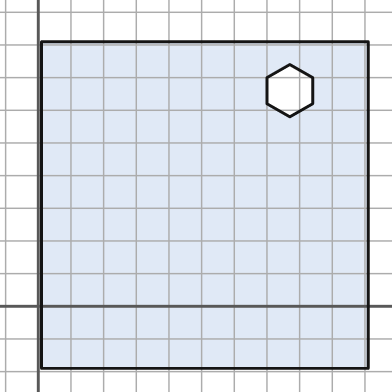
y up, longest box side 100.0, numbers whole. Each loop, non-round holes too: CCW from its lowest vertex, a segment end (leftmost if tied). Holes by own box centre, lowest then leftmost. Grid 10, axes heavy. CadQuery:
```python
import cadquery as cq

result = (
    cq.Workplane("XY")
    .moveTo(1.0, -19.0)
    .lineTo(101.0, -19.0)
    .lineTo(101.0, 81.0)
    .lineTo(1.0, 81.0)
    .close()
    .moveTo(77.0, 58.0)
    .lineTo(84.0, 62.0)
    .lineTo(84.0, 70.0)
    .lineTo(77.0, 74.0)
    .lineTo(70.0, 70.0)
    .lineTo(70.0, 62.0)
    .close()
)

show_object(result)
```